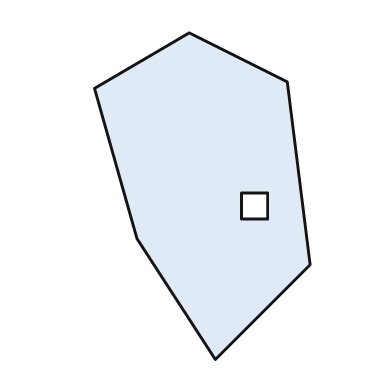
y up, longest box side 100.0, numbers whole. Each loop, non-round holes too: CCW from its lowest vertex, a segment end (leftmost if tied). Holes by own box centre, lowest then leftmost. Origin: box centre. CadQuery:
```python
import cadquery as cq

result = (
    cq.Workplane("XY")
    .moveTo(4.0, -50.0)
    .lineTo(33.0, -21.0)
    .lineTo(26.0, 35.0)
    .lineTo(-4.0, 50.0)
    .lineTo(-33.0, 33.0)
    .lineTo(-20.0, -13.0)
    .close()
    .moveTo(12.0, -7.0)
    .lineTo(20.0, -7.0)
    .lineTo(20.0, 1.0)
    .lineTo(12.0, 1.0)
    .close()
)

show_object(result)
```